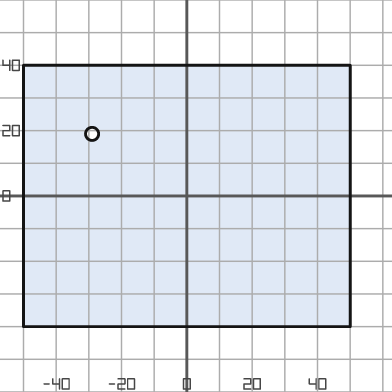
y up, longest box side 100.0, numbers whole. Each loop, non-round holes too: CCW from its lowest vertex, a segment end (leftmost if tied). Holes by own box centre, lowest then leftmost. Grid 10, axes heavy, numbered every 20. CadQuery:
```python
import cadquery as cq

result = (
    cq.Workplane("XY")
    .moveTo(-50.0, -40.0)
    .lineTo(50.0, -40.0)
    .lineTo(50.0, 40.0)
    .lineTo(-50.0, 40.0)
    .close()
    .moveTo(-29.0, 19.0)
    .circle(2.0)
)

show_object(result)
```